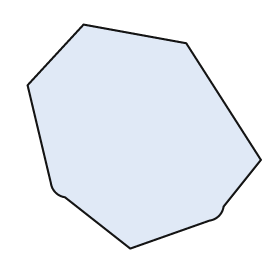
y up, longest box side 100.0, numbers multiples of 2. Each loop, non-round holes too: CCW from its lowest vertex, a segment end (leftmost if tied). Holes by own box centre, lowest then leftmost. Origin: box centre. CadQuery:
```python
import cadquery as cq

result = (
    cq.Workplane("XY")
    .moveTo(-6.0, -48.0)
    .lineTo(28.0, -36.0)
    .threePointArc((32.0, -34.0), (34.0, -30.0))
    .lineTo(50.0, -10.0)
    .lineTo(18.0, 40.0)
    .lineTo(-26.0, 48.0)
    .lineTo(-50.0, 22.0)
    .lineTo(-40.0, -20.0)
    .threePointArc((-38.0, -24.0), (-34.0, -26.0))
    .close()
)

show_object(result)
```